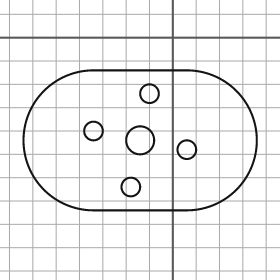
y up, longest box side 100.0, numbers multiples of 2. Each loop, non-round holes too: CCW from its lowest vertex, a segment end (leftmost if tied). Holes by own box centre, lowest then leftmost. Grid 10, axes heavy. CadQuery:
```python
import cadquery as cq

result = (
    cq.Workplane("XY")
    .moveTo(-34.0, -74.0)
    .lineTo(6.0, -74.0)
    .threePointArc((36.0, -44.0), (6.0, -14.0))
    .lineTo(-34.0, -14.0)
    .threePointArc((-64.0, -44.0), (-34.0, -74.0))
    .close()
    .moveTo(-18.0, -64.0)
    .circle(4.0)
    .moveTo(6.0, -48.0)
    .circle(4.0)
    .moveTo(-14.0, -44.0)
    .circle(6.0)
    .moveTo(-34.0, -40.0)
    .circle(4.0)
    .moveTo(-10.0, -24.0)
    .circle(4.0)
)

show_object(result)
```